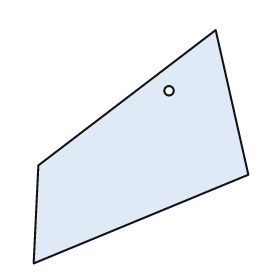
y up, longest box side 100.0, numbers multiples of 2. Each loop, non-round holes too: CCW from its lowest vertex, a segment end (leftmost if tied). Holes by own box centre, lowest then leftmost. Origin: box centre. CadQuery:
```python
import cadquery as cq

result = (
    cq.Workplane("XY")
    .moveTo(-46.0, -50.0)
    .lineTo(46.0, -12.0)
    .lineTo(32.0, 50.0)
    .lineTo(-44.0, -8.0)
    .close()
    .moveTo(12.0, 24.0)
    .circle(2.0)
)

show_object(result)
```